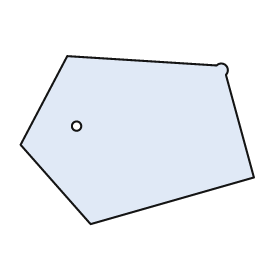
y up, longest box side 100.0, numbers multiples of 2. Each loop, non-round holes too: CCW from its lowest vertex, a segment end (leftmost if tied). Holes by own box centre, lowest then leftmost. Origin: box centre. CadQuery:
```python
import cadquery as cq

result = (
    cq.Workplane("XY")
    .moveTo(-20.0, -36.0)
    .lineTo(50.0, -16.0)
    .lineTo(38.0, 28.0)
    .threePointArc((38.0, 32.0), (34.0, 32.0))
    .lineTo(-30.0, 36.0)
    .lineTo(-50.0, -2.0)
    .close()
    .moveTo(-26.0, 6.0)
    .circle(2.0)
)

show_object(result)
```